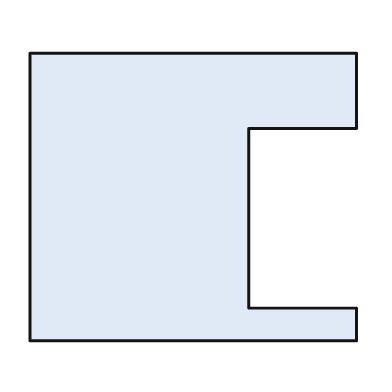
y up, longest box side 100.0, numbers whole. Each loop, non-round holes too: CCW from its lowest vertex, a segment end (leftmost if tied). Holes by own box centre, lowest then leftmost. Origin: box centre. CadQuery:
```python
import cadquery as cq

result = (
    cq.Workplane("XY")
    .moveTo(-50.0, -44.0)
    .lineTo(50.0, -44.0)
    .lineTo(50.0, -34.0)
    .lineTo(17.0, -34.0)
    .lineTo(17.0, 21.0)
    .lineTo(50.0, 21.0)
    .lineTo(50.0, 44.0)
    .lineTo(-50.0, 44.0)
    .close()
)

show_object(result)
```